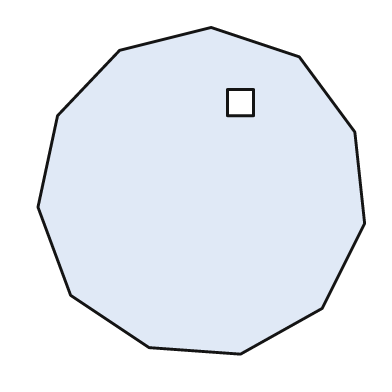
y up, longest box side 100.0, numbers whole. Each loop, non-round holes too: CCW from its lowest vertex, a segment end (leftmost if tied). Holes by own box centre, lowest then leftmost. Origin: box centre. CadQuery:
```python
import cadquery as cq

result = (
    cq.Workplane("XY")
    .moveTo(12.0, -50.0)
    .lineTo(37.0, -36.0)
    .lineTo(50.0, -10.0)
    .lineTo(47.0, 18.0)
    .lineTo(30.0, 41.0)
    .lineTo(3.0, 50.0)
    .lineTo(-25.0, 43.0)
    .lineTo(-44.0, 23.0)
    .lineTo(-50.0, -5.0)
    .lineTo(-40.0, -32.0)
    .lineTo(-16.0, -48.0)
    .close()
    .moveTo(8.0, 23.0)
    .lineTo(16.0, 23.0)
    .lineTo(16.0, 31.0)
    .lineTo(8.0, 31.0)
    .close()
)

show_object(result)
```